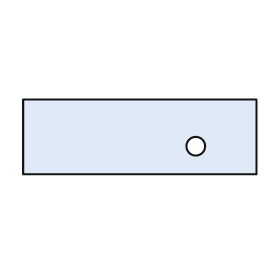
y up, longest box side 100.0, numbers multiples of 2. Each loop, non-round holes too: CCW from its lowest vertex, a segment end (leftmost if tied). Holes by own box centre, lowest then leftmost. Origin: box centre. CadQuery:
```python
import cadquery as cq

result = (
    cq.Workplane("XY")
    .moveTo(-50.0, -16.0)
    .lineTo(50.0, -16.0)
    .lineTo(50.0, 16.0)
    .lineTo(-50.0, 16.0)
    .close()
    .moveTo(24.0, -4.0)
    .circle(4.0)
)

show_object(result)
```